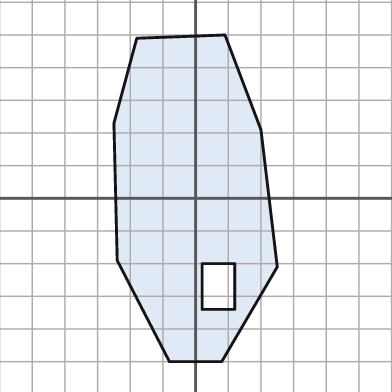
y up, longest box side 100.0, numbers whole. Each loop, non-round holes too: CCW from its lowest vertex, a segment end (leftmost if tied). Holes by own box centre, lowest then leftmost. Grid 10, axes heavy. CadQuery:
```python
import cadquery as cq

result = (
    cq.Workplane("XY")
    .moveTo(-8.0, -50.0)
    .lineTo(8.0, -50.0)
    .lineTo(25.0, -21.0)
    .lineTo(20.0, 21.0)
    .lineTo(9.0, 50.0)
    .lineTo(-18.0, 49.0)
    .lineTo(-25.0, 23.0)
    .lineTo(-24.0, -19.0)
    .close()
    .moveTo(2.0, -34.0)
    .lineTo(12.0, -34.0)
    .lineTo(12.0, -20.0)
    .lineTo(2.0, -20.0)
    .close()
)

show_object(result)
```